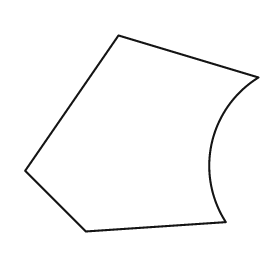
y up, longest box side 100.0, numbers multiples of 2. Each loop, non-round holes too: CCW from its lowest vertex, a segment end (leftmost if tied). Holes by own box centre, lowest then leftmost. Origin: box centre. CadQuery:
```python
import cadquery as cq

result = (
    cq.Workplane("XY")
    .moveTo(-24.0, -42.0)
    .lineTo(36.0, -38.0)
    .threePointArc((30.0, -4.0), (50.0, 24.0))
    .lineTo(-10.0, 42.0)
    .lineTo(-50.0, -16.0)
    .close()
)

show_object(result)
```